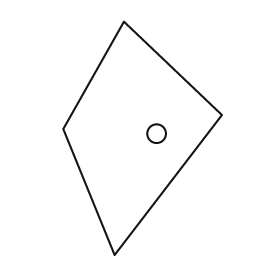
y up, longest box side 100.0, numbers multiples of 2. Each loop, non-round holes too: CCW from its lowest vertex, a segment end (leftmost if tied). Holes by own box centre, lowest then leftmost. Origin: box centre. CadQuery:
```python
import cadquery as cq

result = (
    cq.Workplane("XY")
    .moveTo(-12.0, -50.0)
    .lineTo(34.0, 10.0)
    .lineTo(-8.0, 50.0)
    .lineTo(-34.0, 4.0)
    .close()
    .moveTo(6.0, 2.0)
    .circle(4.0)
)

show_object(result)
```